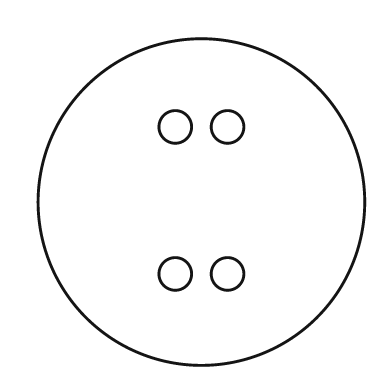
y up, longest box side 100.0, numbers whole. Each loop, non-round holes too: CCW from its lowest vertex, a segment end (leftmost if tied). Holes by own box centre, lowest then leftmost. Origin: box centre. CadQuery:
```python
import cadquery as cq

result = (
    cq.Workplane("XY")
    .moveTo(0.0, 0.0)
    .circle(50.0)
    .moveTo(-8.0, -22.0)
    .circle(5.0)
    .moveTo(8.0, -22.0)
    .circle(5.0)
    .moveTo(-8.0, 23.0)
    .circle(5.0)
    .moveTo(8.0, 23.0)
    .circle(5.0)
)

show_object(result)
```